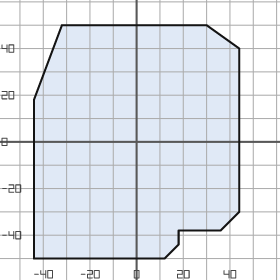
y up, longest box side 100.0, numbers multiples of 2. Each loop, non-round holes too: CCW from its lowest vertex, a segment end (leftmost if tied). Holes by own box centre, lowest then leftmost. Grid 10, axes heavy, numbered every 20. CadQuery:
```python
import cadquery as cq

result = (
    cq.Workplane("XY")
    .moveTo(-44.0, -50.0)
    .lineTo(12.0, -50.0)
    .lineTo(18.0, -44.0)
    .lineTo(18.0, -38.0)
    .lineTo(36.0, -38.0)
    .lineTo(44.0, -30.0)
    .lineTo(44.0, 40.0)
    .lineTo(30.0, 50.0)
    .lineTo(-32.0, 50.0)
    .lineTo(-44.0, 18.0)
    .close()
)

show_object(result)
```